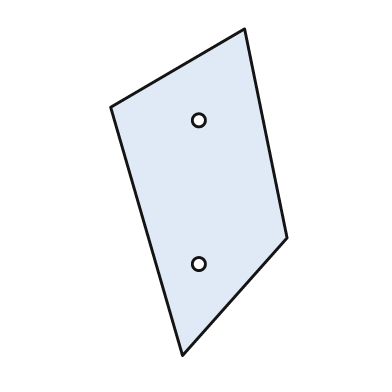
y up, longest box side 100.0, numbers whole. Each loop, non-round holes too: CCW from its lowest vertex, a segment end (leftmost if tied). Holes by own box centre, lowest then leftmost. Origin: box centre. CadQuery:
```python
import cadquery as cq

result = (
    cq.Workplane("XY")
    .moveTo(-5.0, -50.0)
    .lineTo(27.0, -14.0)
    .lineTo(14.0, 50.0)
    .lineTo(-27.0, 26.0)
    .close()
    .moveTo(0.0, -22.0)
    .circle(2.0)
    .moveTo(0.0, 22.0)
    .circle(2.0)
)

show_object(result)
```